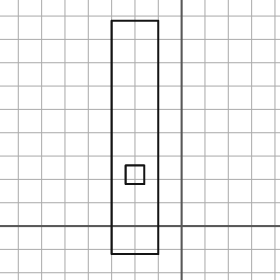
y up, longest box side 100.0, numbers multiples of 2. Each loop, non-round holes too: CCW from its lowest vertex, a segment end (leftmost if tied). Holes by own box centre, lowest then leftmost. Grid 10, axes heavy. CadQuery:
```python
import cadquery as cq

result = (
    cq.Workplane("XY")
    .moveTo(-30.0, -12.0)
    .lineTo(-10.0, -12.0)
    .lineTo(-10.0, 88.0)
    .lineTo(-30.0, 88.0)
    .close()
    .moveTo(-24.0, 18.0)
    .lineTo(-16.0, 18.0)
    .lineTo(-16.0, 26.0)
    .lineTo(-24.0, 26.0)
    .close()
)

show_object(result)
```